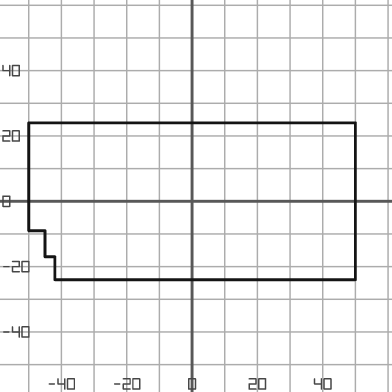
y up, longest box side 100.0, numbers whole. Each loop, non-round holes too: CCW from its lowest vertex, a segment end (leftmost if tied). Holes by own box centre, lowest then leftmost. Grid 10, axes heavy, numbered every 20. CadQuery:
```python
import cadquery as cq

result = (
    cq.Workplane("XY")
    .moveTo(-42.0, -24.0)
    .lineTo(50.0, -24.0)
    .lineTo(50.0, 24.0)
    .lineTo(-50.0, 24.0)
    .lineTo(-50.0, -9.0)
    .lineTo(-45.0, -9.0)
    .lineTo(-45.0, -17.0)
    .lineTo(-42.0, -17.0)
    .close()
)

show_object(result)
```